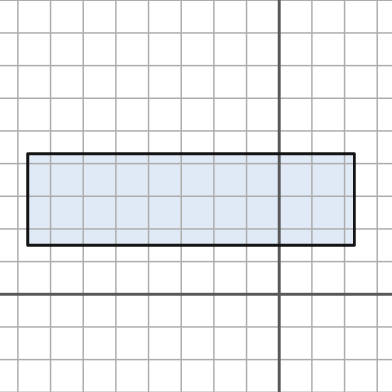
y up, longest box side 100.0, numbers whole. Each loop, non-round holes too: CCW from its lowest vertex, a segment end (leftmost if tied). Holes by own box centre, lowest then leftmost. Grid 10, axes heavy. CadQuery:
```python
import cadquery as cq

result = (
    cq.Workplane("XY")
    .moveTo(-77.0, 15.0)
    .lineTo(23.0, 15.0)
    .lineTo(23.0, 43.0)
    .lineTo(-77.0, 43.0)
    .close()
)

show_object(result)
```